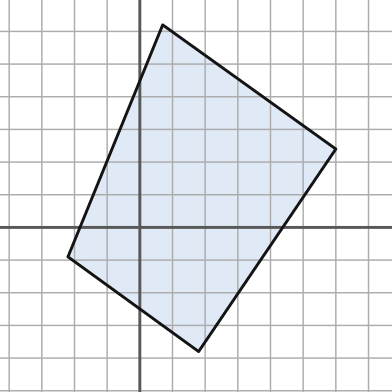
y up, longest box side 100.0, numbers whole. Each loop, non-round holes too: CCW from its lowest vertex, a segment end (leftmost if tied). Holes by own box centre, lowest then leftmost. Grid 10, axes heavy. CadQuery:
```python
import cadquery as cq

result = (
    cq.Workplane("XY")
    .moveTo(18.0, -38.0)
    .lineTo(60.0, 24.0)
    .lineTo(7.0, 62.0)
    .lineTo(-22.0, -9.0)
    .close()
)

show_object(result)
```